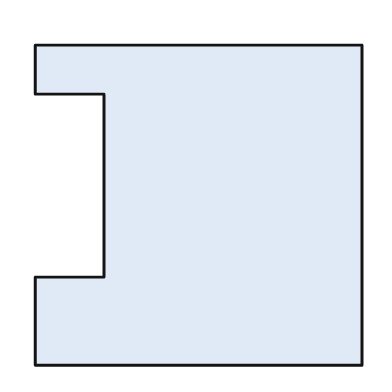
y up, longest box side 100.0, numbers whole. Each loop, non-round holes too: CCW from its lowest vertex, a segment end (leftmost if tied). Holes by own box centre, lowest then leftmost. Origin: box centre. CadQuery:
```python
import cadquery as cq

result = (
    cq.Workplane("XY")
    .moveTo(-50.0, -49.0)
    .lineTo(50.0, -49.0)
    .lineTo(50.0, 49.0)
    .lineTo(-50.0, 49.0)
    .lineTo(-50.0, 34.0)
    .lineTo(-29.0, 34.0)
    .lineTo(-29.0, -22.0)
    .lineTo(-50.0, -22.0)
    .close()
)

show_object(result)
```